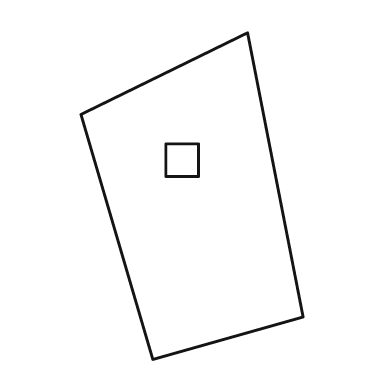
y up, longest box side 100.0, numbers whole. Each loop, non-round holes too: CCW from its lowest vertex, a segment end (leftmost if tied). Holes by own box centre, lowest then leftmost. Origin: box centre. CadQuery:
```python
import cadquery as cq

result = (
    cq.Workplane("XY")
    .moveTo(-12.0, -50.0)
    .lineTo(34.0, -37.0)
    .lineTo(17.0, 50.0)
    .lineTo(-34.0, 25.0)
    .close()
    .moveTo(-8.0, 6.0)
    .lineTo(2.0, 6.0)
    .lineTo(2.0, 16.0)
    .lineTo(-8.0, 16.0)
    .close()
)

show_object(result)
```